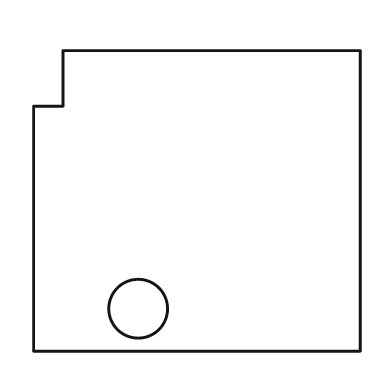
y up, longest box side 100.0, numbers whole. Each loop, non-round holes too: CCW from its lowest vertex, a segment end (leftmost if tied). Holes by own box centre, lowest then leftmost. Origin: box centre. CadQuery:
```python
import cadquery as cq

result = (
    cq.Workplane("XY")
    .moveTo(-50.0, -46.0)
    .lineTo(50.0, -46.0)
    .lineTo(50.0, 46.0)
    .lineTo(-41.0, 46.0)
    .lineTo(-41.0, 29.0)
    .lineTo(-50.0, 29.0)
    .close()
    .moveTo(-18.0, -33.0)
    .circle(9.0)
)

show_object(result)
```